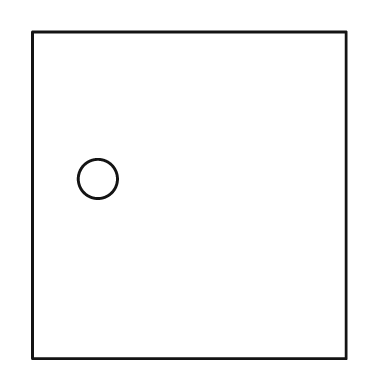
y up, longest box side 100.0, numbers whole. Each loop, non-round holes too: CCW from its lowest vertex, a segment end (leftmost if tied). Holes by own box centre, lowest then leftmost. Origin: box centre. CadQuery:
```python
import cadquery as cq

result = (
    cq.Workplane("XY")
    .moveTo(-48.0, -50.0)
    .lineTo(48.0, -50.0)
    .lineTo(48.0, 50.0)
    .lineTo(-48.0, 50.0)
    .close()
    .moveTo(-28.0, 5.0)
    .circle(6.0)
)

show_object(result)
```